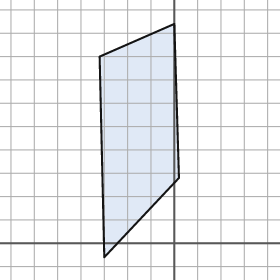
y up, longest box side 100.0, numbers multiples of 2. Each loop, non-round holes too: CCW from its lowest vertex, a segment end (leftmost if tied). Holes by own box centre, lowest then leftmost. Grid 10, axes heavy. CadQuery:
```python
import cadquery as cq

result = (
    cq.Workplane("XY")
    .moveTo(-30.0, -6.0)
    .lineTo(2.0, 28.0)
    .lineTo(0.0, 94.0)
    .lineTo(-32.0, 80.0)
    .close()
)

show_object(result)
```